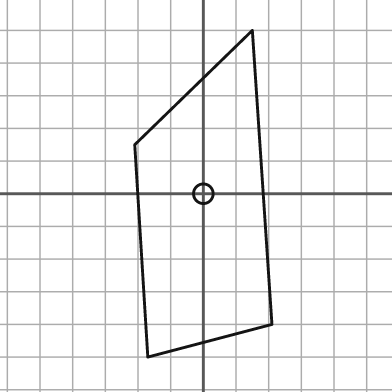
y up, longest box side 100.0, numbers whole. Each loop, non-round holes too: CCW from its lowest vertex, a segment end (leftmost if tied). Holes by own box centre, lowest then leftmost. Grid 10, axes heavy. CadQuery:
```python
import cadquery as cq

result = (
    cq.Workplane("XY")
    .moveTo(-17.0, -50.0)
    .lineTo(21.0, -40.0)
    .lineTo(15.0, 50.0)
    .lineTo(-21.0, 15.0)
    .close()
    .moveTo(0.0, 0.0)
    .circle(3.0)
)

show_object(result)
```